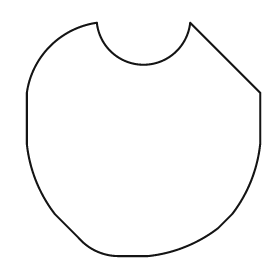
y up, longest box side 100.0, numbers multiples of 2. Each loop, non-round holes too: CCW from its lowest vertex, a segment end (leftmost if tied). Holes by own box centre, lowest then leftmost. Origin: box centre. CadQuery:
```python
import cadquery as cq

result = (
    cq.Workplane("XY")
    .moveTo(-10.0, -50.0)
    .lineTo(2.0, -50.0)
    .threePointArc((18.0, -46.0), (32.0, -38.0))
    .lineTo(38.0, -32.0)
    .threePointArc((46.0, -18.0), (50.0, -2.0))
    .lineTo(50.0, 20.0)
    .lineTo(20.0, 50.0)
    .threePointArc((0.0, 32.0), (-20.0, 50.0))
    .threePointArc((-40.0, 40.0), (-50.0, 20.0))
    .lineTo(-50.0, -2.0)
    .threePointArc((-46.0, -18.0), (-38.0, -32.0))
    .lineTo(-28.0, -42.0)
    .threePointArc((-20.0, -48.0), (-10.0, -50.0))
    .close()
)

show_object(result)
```